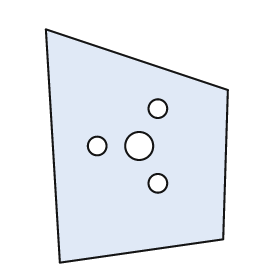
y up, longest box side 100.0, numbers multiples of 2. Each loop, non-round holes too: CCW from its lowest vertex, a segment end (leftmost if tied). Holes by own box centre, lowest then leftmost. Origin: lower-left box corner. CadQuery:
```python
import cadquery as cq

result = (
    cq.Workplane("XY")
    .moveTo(6.0, 0.0)
    .lineTo(76.0, 10.0)
    .lineTo(78.0, 74.0)
    .lineTo(0.0, 100.0)
    .close()
    .moveTo(48.0, 34.0)
    .circle(4.0)
    .moveTo(22.0, 50.0)
    .circle(4.0)
    .moveTo(40.0, 50.0)
    .circle(6.0)
    .moveTo(48.0, 66.0)
    .circle(4.0)
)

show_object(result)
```